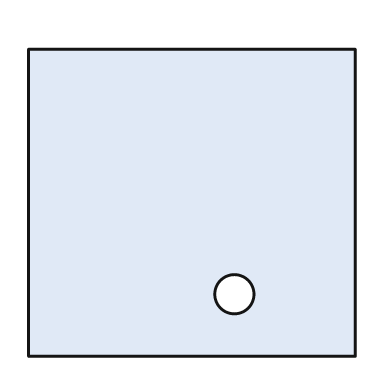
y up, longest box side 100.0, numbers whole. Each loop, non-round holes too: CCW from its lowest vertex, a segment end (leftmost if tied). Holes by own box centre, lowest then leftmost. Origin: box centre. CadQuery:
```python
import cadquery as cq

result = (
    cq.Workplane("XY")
    .moveTo(-50.0, -47.0)
    .lineTo(50.0, -47.0)
    .lineTo(50.0, 47.0)
    .lineTo(-50.0, 47.0)
    .close()
    .moveTo(13.0, -28.0)
    .circle(6.0)
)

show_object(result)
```